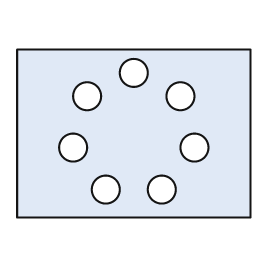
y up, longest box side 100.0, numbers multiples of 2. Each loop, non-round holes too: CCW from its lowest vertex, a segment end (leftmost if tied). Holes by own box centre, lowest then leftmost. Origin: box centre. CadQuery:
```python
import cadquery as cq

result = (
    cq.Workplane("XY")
    .moveTo(-50.0, -36.0)
    .lineTo(50.0, -36.0)
    .lineTo(50.0, 36.0)
    .lineTo(-50.0, 36.0)
    .close()
    .moveTo(-12.0, -24.0)
    .circle(6.0)
    .moveTo(12.0, -24.0)
    .circle(6.0)
    .moveTo(-26.0, -6.0)
    .circle(6.0)
    .moveTo(26.0, -6.0)
    .circle(6.0)
    .moveTo(-20.0, 16.0)
    .circle(6.0)
    .moveTo(20.0, 16.0)
    .circle(6.0)
    .moveTo(0.0, 26.0)
    .circle(6.0)
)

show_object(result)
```